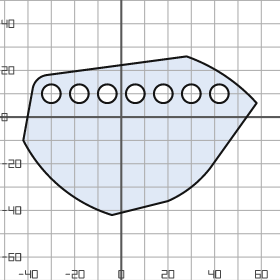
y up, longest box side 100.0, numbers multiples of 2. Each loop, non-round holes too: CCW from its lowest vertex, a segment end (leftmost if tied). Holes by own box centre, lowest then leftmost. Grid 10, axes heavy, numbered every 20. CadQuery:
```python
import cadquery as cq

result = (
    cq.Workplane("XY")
    .moveTo(-4.0, -42.0)
    .lineTo(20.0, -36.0)
    .threePointArc((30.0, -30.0), (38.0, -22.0))
    .lineTo(58.0, 6.0)
    .threePointArc((44.0, 18.0), (28.0, 26.0))
    .lineTo(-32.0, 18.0)
    .threePointArc((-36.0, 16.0), (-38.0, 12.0))
    .lineTo(-42.0, -10.0)
    .threePointArc((-26.0, -30.0), (-4.0, -42.0))
    .close()
    .moveTo(-30.0, 10.0)
    .circle(4.0)
    .moveTo(-18.0, 10.0)
    .circle(4.0)
    .moveTo(-6.0, 10.0)
    .circle(4.0)
    .moveTo(6.0, 10.0)
    .circle(4.0)
    .moveTo(18.0, 10.0)
    .circle(4.0)
    .moveTo(30.0, 10.0)
    .circle(4.0)
    .moveTo(42.0, 10.0)
    .circle(4.0)
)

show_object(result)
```